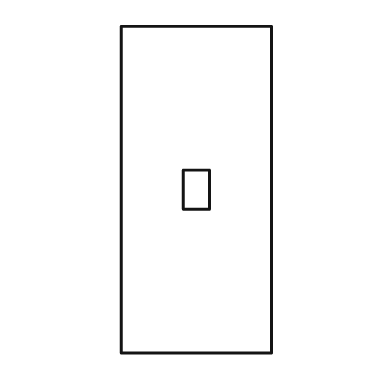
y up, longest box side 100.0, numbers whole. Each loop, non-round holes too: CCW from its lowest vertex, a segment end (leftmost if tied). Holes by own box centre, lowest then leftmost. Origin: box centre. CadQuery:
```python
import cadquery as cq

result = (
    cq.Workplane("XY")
    .moveTo(-23.0, -50.0)
    .lineTo(23.0, -50.0)
    .lineTo(23.0, 50.0)
    .lineTo(-23.0, 50.0)
    .close()
    .moveTo(-4.0, -6.0)
    .lineTo(4.0, -6.0)
    .lineTo(4.0, 6.0)
    .lineTo(-4.0, 6.0)
    .close()
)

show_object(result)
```